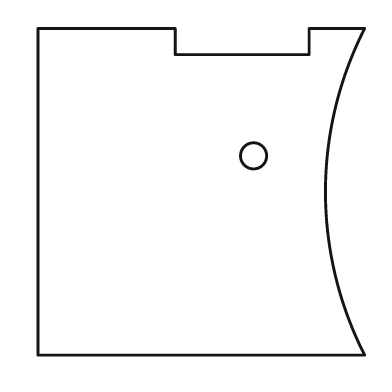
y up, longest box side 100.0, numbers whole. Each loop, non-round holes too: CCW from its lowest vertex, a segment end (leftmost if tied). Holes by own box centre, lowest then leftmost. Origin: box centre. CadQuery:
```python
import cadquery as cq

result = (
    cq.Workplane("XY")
    .moveTo(-50.0, -50.0)
    .lineTo(50.0, -50.0)
    .threePointArc((38.0, 0.0), (50.0, 50.0))
    .lineTo(33.0, 50.0)
    .lineTo(33.0, 42.0)
    .lineTo(-8.0, 42.0)
    .lineTo(-8.0, 50.0)
    .lineTo(-50.0, 50.0)
    .close()
    .moveTo(16.0, 11.0)
    .circle(4.0)
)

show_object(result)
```